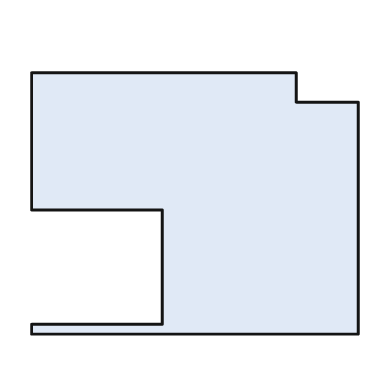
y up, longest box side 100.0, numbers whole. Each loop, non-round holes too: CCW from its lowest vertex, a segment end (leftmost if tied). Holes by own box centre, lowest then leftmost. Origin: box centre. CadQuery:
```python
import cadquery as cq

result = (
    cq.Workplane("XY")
    .moveTo(-50.0, -40.0)
    .lineTo(50.0, -40.0)
    .lineTo(50.0, 31.0)
    .lineTo(31.0, 31.0)
    .lineTo(31.0, 40.0)
    .lineTo(-50.0, 40.0)
    .lineTo(-50.0, -2.0)
    .lineTo(-10.0, -2.0)
    .lineTo(-10.0, -37.0)
    .lineTo(-50.0, -37.0)
    .close()
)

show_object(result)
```